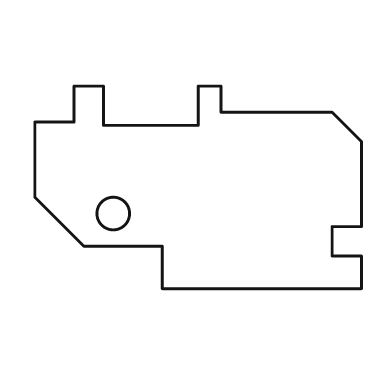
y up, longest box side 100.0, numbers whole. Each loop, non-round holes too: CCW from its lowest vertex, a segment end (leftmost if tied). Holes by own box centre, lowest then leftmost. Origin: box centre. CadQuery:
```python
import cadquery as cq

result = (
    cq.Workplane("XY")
    .moveTo(-11.0, -31.0)
    .lineTo(50.0, -31.0)
    .lineTo(50.0, -21.0)
    .lineTo(41.0, -21.0)
    .lineTo(41.0, -12.0)
    .lineTo(50.0, -12.0)
    .lineTo(50.0, 14.0)
    .lineTo(41.0, 23.0)
    .lineTo(7.0, 23.0)
    .lineTo(7.0, 31.0)
    .lineTo(0.0, 31.0)
    .lineTo(0.0, 19.0)
    .lineTo(-29.0, 19.0)
    .lineTo(-29.0, 31.0)
    .lineTo(-38.0, 31.0)
    .lineTo(-38.0, 20.0)
    .lineTo(-50.0, 20.0)
    .lineTo(-50.0, -3.0)
    .lineTo(-35.0, -18.0)
    .lineTo(-11.0, -18.0)
    .close()
    .moveTo(-26.0, -8.0)
    .circle(5.0)
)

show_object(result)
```